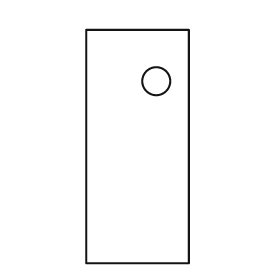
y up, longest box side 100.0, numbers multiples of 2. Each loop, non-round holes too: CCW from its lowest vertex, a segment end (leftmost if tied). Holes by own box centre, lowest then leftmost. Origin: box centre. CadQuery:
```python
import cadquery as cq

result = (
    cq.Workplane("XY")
    .moveTo(-22.0, -50.0)
    .lineTo(22.0, -50.0)
    .lineTo(22.0, 50.0)
    .lineTo(-22.0, 50.0)
    .close()
    .moveTo(8.0, 28.0)
    .circle(6.0)
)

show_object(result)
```